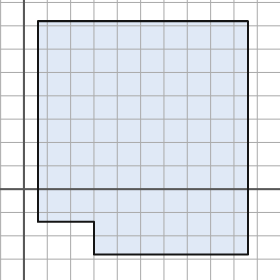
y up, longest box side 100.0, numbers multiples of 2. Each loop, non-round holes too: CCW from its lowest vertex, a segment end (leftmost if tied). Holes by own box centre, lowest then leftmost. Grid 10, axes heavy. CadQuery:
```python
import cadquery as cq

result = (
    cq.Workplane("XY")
    .moveTo(30.0, -28.0)
    .lineTo(96.0, -28.0)
    .lineTo(96.0, 72.0)
    .lineTo(6.0, 72.0)
    .lineTo(6.0, -14.0)
    .lineTo(30.0, -14.0)
    .close()
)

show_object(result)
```